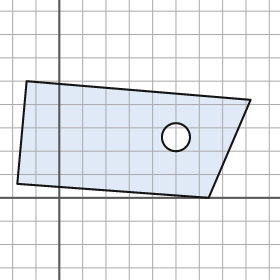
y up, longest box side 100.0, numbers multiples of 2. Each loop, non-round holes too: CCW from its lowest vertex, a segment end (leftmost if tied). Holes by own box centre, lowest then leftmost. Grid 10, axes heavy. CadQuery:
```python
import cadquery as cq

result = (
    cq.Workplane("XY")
    .moveTo(64.0, 0.0)
    .lineTo(82.0, 42.0)
    .lineTo(-14.0, 50.0)
    .lineTo(-18.0, 6.0)
    .close()
    .moveTo(50.0, 26.0)
    .circle(6.0)
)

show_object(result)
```